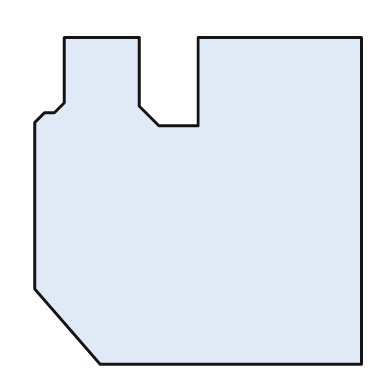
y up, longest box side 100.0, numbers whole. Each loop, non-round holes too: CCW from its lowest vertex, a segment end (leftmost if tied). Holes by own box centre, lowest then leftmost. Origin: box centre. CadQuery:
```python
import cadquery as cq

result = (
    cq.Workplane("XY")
    .moveTo(-30.0, -50.0)
    .lineTo(50.0, -50.0)
    .lineTo(50.0, 50.0)
    .lineTo(0.0, 50.0)
    .lineTo(0.0, 23.0)
    .lineTo(-12.0, 23.0)
    .lineTo(-18.0, 29.0)
    .lineTo(-18.0, 50.0)
    .lineTo(-41.0, 50.0)
    .lineTo(-41.0, 30.0)
    .lineTo(-44.0, 27.0)
    .lineTo(-47.0, 27.0)
    .lineTo(-50.0, 24.0)
    .lineTo(-50.0, -27.0)
    .close()
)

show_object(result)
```